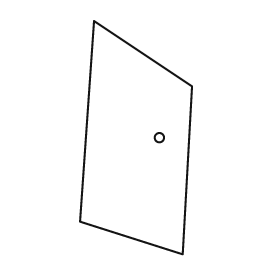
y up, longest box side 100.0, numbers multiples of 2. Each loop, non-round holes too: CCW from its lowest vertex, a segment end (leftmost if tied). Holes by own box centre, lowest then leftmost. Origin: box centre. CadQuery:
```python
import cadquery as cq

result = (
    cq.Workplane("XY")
    .moveTo(20.0, -50.0)
    .lineTo(24.0, 22.0)
    .lineTo(-18.0, 50.0)
    .lineTo(-24.0, -36.0)
    .close()
    .moveTo(10.0, 0.0)
    .circle(2.0)
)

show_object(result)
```